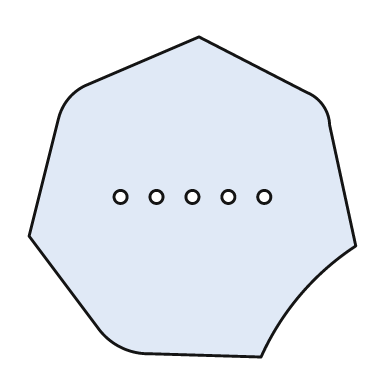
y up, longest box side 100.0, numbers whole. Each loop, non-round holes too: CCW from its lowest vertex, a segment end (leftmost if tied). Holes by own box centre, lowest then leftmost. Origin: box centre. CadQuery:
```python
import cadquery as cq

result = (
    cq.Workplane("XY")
    .moveTo(21.0, -49.0)
    .threePointArc((33.0, -30.0), (50.0, -15.0))
    .lineTo(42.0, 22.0)
    .threePointArc((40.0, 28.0), (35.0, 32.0))
    .lineTo(2.0, 49.0)
    .lineTo(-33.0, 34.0)
    .threePointArc((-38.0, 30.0), (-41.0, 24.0))
    .lineTo(-50.0, -12.0)
    .lineTo(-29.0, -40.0)
    .threePointArc((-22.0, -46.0), (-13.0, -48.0))
    .close()
    .moveTo(-22.0, 0.0)
    .circle(2.0)
    .moveTo(-11.0, 0.0)
    .circle(2.0)
    .moveTo(0.0, 0.0)
    .circle(2.0)
    .moveTo(11.0, 0.0)
    .circle(2.0)
    .moveTo(22.0, 0.0)
    .circle(2.0)
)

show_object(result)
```